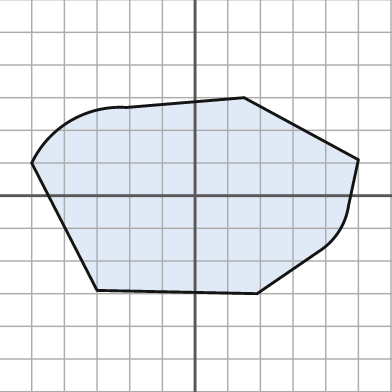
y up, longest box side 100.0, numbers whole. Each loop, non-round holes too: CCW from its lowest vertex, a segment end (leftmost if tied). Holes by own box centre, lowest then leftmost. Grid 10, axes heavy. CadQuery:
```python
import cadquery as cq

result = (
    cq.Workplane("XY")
    .moveTo(19.0, -30.0)
    .lineTo(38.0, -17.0)
    .threePointArc((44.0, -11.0), (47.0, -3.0))
    .lineTo(50.0, 11.0)
    .lineTo(15.0, 30.0)
    .lineTo(-21.0, 27.0)
    .threePointArc((-38.0, 23.0), (-50.0, 10.0))
    .lineTo(-30.0, -29.0)
    .close()
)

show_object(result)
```